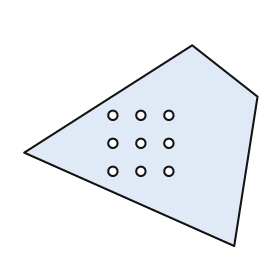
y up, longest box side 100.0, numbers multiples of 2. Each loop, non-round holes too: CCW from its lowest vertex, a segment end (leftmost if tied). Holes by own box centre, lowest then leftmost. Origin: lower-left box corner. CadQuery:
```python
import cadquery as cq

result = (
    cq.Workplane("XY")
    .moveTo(90.0, 0.0)
    .lineTo(100.0, 64.0)
    .lineTo(72.0, 86.0)
    .lineTo(0.0, 40.0)
    .close()
    .moveTo(38.0, 32.0)
    .circle(2.0)
    .moveTo(50.0, 32.0)
    .circle(2.0)
    .moveTo(62.0, 32.0)
    .circle(2.0)
    .moveTo(38.0, 44.0)
    .circle(2.0)
    .moveTo(50.0, 44.0)
    .circle(2.0)
    .moveTo(62.0, 44.0)
    .circle(2.0)
    .moveTo(38.0, 56.0)
    .circle(2.0)
    .moveTo(50.0, 56.0)
    .circle(2.0)
    .moveTo(62.0, 56.0)
    .circle(2.0)
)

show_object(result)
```